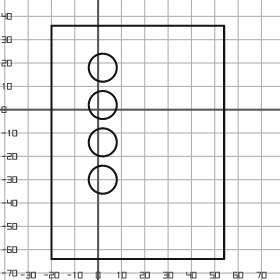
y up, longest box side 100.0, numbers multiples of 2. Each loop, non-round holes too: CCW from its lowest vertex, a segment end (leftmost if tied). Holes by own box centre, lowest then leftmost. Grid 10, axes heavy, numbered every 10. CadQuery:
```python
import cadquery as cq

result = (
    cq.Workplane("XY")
    .moveTo(-20.0, -64.0)
    .lineTo(54.0, -64.0)
    .lineTo(54.0, 36.0)
    .lineTo(-20.0, 36.0)
    .close()
    .moveTo(2.0, -30.0)
    .circle(6.0)
    .moveTo(2.0, -14.0)
    .circle(6.0)
    .moveTo(2.0, 2.0)
    .circle(6.0)
    .moveTo(2.0, 18.0)
    .circle(6.0)
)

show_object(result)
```